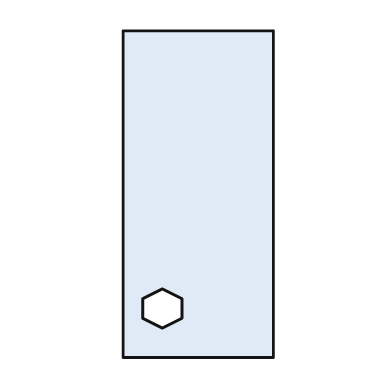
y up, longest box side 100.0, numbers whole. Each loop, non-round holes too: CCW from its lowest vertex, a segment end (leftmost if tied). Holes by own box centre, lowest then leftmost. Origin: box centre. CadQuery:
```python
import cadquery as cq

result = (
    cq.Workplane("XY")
    .moveTo(-23.0, -50.0)
    .lineTo(23.0, -50.0)
    .lineTo(23.0, 50.0)
    .lineTo(-23.0, 50.0)
    .close()
    .moveTo(-11.0, -41.0)
    .lineTo(-5.0, -38.0)
    .lineTo(-5.0, -32.0)
    .lineTo(-11.0, -29.0)
    .lineTo(-17.0, -32.0)
    .lineTo(-17.0, -38.0)
    .close()
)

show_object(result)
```